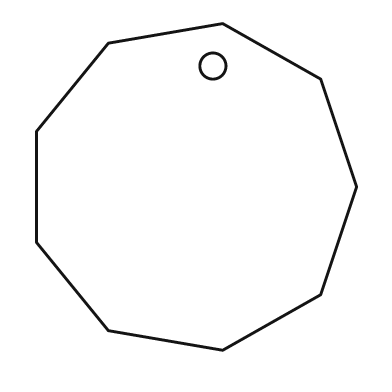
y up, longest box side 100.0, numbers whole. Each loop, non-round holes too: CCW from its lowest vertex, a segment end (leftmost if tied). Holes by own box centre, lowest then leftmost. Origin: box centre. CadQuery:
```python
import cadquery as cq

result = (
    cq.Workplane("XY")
    .moveTo(8.0, -50.0)
    .lineTo(38.0, -33.0)
    .lineTo(49.0, 0.0)
    .lineTo(38.0, 33.0)
    .lineTo(8.0, 50.0)
    .lineTo(-27.0, 44.0)
    .lineTo(-49.0, 17.0)
    .lineTo(-49.0, -17.0)
    .lineTo(-27.0, -44.0)
    .close()
    .moveTo(5.0, 37.0)
    .circle(4.0)
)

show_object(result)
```